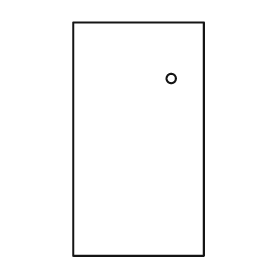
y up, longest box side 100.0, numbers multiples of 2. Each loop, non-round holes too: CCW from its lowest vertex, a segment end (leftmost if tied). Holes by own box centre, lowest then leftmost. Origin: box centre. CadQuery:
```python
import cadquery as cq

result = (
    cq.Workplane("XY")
    .moveTo(-28.0, -50.0)
    .lineTo(28.0, -50.0)
    .lineTo(28.0, 50.0)
    .lineTo(-28.0, 50.0)
    .close()
    .moveTo(14.0, 26.0)
    .circle(2.0)
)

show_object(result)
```